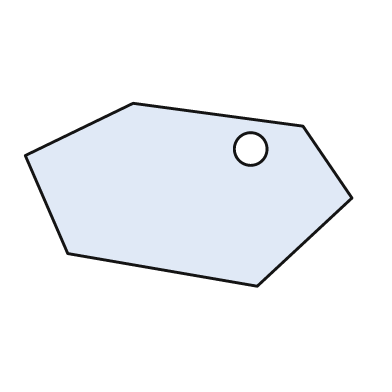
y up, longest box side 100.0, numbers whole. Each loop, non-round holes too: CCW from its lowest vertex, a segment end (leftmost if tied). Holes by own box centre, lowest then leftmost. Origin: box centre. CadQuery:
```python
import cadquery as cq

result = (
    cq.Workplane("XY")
    .moveTo(21.0, -28.0)
    .lineTo(50.0, -1.0)
    .lineTo(35.0, 21.0)
    .lineTo(-17.0, 28.0)
    .lineTo(-50.0, 12.0)
    .lineTo(-37.0, -18.0)
    .close()
    .moveTo(19.0, 14.0)
    .circle(5.0)
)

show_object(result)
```